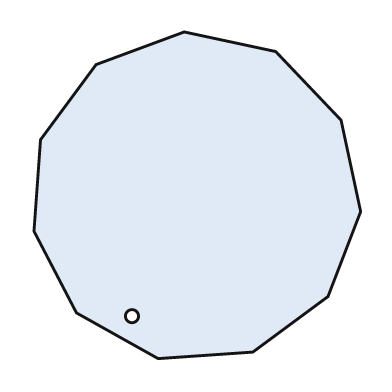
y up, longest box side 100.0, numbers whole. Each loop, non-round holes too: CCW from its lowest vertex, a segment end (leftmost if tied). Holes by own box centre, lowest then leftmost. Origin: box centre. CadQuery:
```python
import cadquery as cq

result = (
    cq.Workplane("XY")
    .moveTo(-12.0, -50.0)
    .lineTo(17.0, -48.0)
    .lineTo(40.0, -31.0)
    .lineTo(50.0, -5.0)
    .lineTo(44.0, 23.0)
    .lineTo(24.0, 44.0)
    .lineTo(-4.0, 50.0)
    .lineTo(-31.0, 40.0)
    .lineTo(-48.0, 17.0)
    .lineTo(-50.0, -11.0)
    .lineTo(-37.0, -36.0)
    .close()
    .moveTo(-20.0, -37.0)
    .circle(2.0)
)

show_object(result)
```